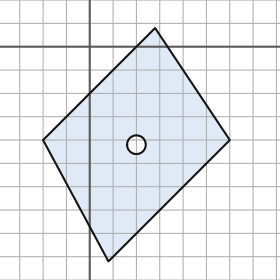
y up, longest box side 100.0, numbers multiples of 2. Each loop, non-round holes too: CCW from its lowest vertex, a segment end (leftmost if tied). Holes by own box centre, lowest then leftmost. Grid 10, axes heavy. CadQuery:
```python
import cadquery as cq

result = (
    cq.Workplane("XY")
    .moveTo(8.0, -92.0)
    .lineTo(60.0, -40.0)
    .lineTo(28.0, 8.0)
    .lineTo(-20.0, -40.0)
    .close()
    .moveTo(20.0, -42.0)
    .circle(4.0)
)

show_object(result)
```